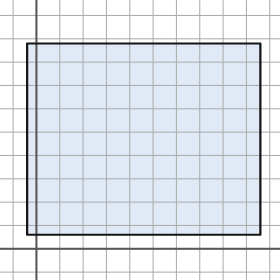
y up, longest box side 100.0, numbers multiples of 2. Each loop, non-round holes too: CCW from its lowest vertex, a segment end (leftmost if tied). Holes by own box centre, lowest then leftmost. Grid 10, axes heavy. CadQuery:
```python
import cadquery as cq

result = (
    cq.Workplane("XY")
    .moveTo(-4.0, 6.0)
    .lineTo(96.0, 6.0)
    .lineTo(96.0, 88.0)
    .lineTo(-4.0, 88.0)
    .close()
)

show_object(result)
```